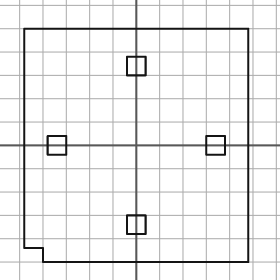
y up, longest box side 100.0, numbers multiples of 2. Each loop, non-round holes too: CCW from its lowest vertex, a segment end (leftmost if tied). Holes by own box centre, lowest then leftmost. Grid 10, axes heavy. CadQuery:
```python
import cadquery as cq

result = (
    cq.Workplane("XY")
    .moveTo(-40.0, -50.0)
    .lineTo(48.0, -50.0)
    .lineTo(48.0, 50.0)
    .lineTo(-48.0, 50.0)
    .lineTo(-48.0, -44.0)
    .lineTo(-40.0, -44.0)
    .close()
    .moveTo(-4.0, -38.0)
    .lineTo(4.0, -38.0)
    .lineTo(4.0, -30.0)
    .lineTo(-4.0, -30.0)
    .close()
    .moveTo(-38.0, -4.0)
    .lineTo(-30.0, -4.0)
    .lineTo(-30.0, 4.0)
    .lineTo(-38.0, 4.0)
    .close()
    .moveTo(30.0, -4.0)
    .lineTo(38.0, -4.0)
    .lineTo(38.0, 4.0)
    .lineTo(30.0, 4.0)
    .close()
    .moveTo(-4.0, 30.0)
    .lineTo(4.0, 30.0)
    .lineTo(4.0, 38.0)
    .lineTo(-4.0, 38.0)
    .close()
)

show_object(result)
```